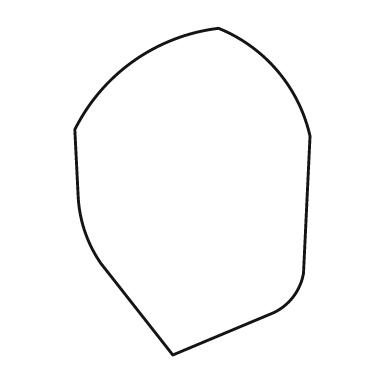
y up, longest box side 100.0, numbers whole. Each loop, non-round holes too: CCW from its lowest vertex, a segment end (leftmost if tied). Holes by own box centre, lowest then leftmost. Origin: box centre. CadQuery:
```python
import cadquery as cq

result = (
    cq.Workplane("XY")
    .moveTo(-6.0, -50.0)
    .lineTo(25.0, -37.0)
    .threePointArc((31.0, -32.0), (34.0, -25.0))
    .lineTo(36.0, 17.0)
    .threePointArc((26.0, 37.0), (8.0, 50.0))
    .threePointArc((-18.0, 40.0), (-36.0, 19.0))
    .lineTo(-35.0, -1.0)
    .threePointArc((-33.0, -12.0), (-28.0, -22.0))
    .close()
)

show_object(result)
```